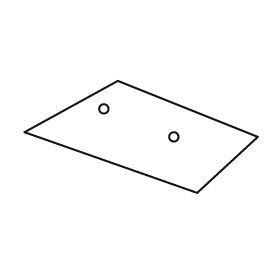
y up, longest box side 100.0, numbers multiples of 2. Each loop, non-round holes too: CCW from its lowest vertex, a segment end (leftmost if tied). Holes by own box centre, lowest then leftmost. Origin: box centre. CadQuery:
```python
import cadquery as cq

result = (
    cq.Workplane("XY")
    .moveTo(24.0, -24.0)
    .lineTo(50.0, 0.0)
    .lineTo(-10.0, 24.0)
    .lineTo(-50.0, 2.0)
    .close()
    .moveTo(14.0, 0.0)
    .circle(2.0)
    .moveTo(-16.0, 12.0)
    .circle(2.0)
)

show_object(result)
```